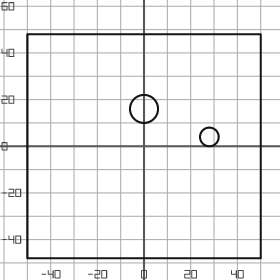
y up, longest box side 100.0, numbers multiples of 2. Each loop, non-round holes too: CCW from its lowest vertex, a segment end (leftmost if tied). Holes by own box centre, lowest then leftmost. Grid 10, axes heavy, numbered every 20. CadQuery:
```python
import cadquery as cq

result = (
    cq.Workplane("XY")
    .moveTo(-50.0, -48.0)
    .lineTo(50.0, -48.0)
    .lineTo(50.0, 48.0)
    .lineTo(-50.0, 48.0)
    .close()
    .moveTo(28.0, 4.0)
    .circle(4.0)
    .moveTo(0.0, 16.0)
    .circle(6.0)
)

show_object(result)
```